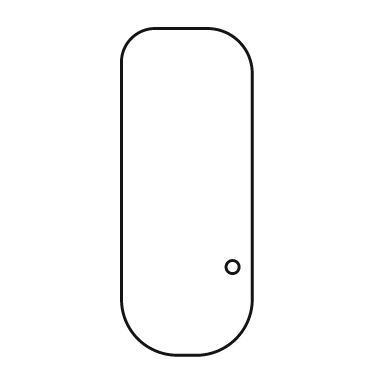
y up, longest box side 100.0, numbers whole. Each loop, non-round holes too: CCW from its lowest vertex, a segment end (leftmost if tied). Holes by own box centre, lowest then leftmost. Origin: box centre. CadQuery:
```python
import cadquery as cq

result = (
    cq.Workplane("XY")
    .moveTo(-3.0, -50.0)
    .lineTo(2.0, -50.0)
    .threePointArc((15.0, -45.0), (20.0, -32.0))
    .lineTo(20.0, 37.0)
    .threePointArc((16.0, 46.0), (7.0, 50.0))
    .lineTo(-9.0, 50.0)
    .threePointArc((-17.0, 47.0), (-20.0, 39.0))
    .lineTo(-20.0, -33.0)
    .threePointArc((-15.0, -45.0), (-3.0, -50.0))
    .close()
    .moveTo(14.0, -23.0)
    .circle(2.0)
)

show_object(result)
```